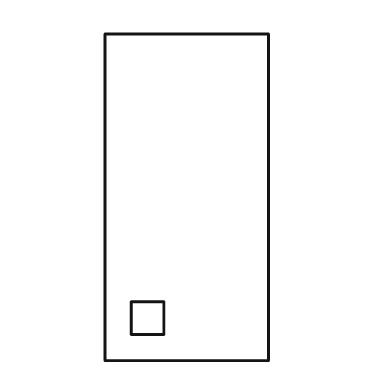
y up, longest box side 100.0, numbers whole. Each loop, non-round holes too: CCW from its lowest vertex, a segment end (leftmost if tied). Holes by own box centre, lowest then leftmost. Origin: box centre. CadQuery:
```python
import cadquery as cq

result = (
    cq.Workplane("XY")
    .moveTo(-25.0, -50.0)
    .lineTo(25.0, -50.0)
    .lineTo(25.0, 50.0)
    .lineTo(-25.0, 50.0)
    .close()
    .moveTo(-17.0, -42.0)
    .lineTo(-7.0, -42.0)
    .lineTo(-7.0, -32.0)
    .lineTo(-17.0, -32.0)
    .close()
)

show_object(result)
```